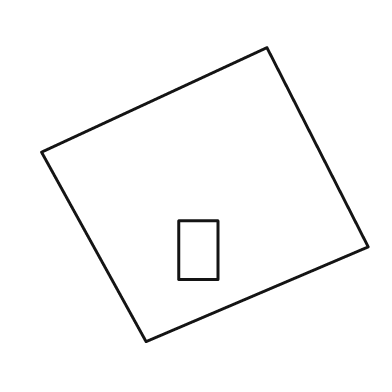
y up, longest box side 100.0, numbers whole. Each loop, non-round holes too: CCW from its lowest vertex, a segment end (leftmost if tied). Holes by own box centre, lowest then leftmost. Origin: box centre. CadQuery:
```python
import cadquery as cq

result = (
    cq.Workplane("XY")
    .moveTo(-18.0, -45.0)
    .lineTo(50.0, -16.0)
    .lineTo(19.0, 45.0)
    .lineTo(-50.0, 13.0)
    .close()
    .moveTo(-8.0, -26.0)
    .lineTo(4.0, -26.0)
    .lineTo(4.0, -8.0)
    .lineTo(-8.0, -8.0)
    .close()
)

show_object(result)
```